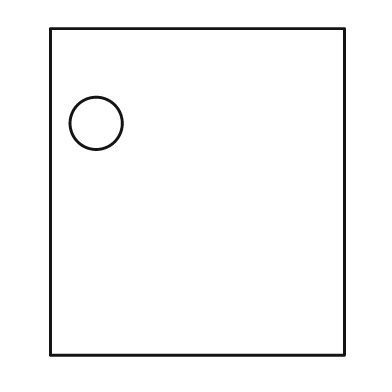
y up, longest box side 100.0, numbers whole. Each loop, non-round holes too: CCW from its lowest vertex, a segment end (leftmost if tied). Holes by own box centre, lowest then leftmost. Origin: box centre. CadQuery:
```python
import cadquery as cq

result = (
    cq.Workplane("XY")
    .moveTo(-45.0, -50.0)
    .lineTo(45.0, -50.0)
    .lineTo(45.0, 50.0)
    .lineTo(-45.0, 50.0)
    .close()
    .moveTo(-31.0, 21.0)
    .circle(8.0)
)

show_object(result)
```